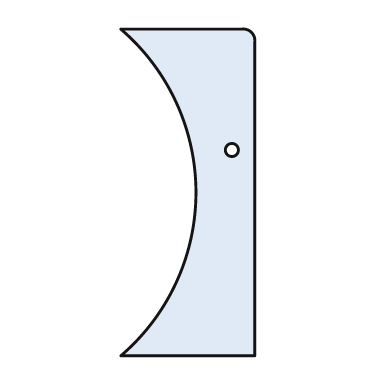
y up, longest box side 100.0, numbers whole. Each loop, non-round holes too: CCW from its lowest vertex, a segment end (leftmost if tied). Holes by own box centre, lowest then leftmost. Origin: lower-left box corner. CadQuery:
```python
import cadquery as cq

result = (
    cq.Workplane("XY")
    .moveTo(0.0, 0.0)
    .lineTo(41.0, 0.0)
    .lineTo(41.0, 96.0)
    .threePointArc((40.0, 99.0), (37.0, 100.0))
    .lineTo(0.0, 100.0)
    .threePointArc((23.0, 50.0), (0.0, 0.0))
    .close()
    .moveTo(34.0, 63.0)
    .circle(2.0)
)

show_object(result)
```